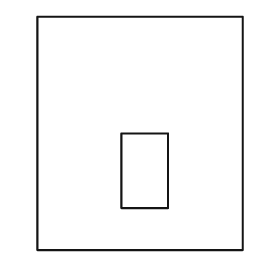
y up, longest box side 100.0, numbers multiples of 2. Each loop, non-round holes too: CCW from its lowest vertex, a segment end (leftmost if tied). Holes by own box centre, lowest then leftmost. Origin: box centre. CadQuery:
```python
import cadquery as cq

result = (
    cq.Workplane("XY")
    .moveTo(-44.0, -50.0)
    .lineTo(44.0, -50.0)
    .lineTo(44.0, 50.0)
    .lineTo(-44.0, 50.0)
    .close()
    .moveTo(-8.0, -32.0)
    .lineTo(12.0, -32.0)
    .lineTo(12.0, 0.0)
    .lineTo(-8.0, 0.0)
    .close()
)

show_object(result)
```